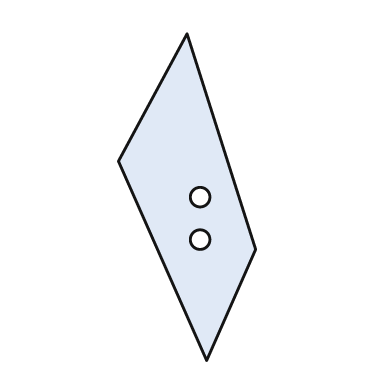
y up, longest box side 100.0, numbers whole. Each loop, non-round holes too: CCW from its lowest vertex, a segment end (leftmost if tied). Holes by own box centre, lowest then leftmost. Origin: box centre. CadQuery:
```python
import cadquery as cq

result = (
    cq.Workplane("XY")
    .moveTo(6.0, -50.0)
    .lineTo(21.0, -16.0)
    .lineTo(0.0, 50.0)
    .lineTo(-21.0, 11.0)
    .close()
    .moveTo(4.0, -13.0)
    .circle(3.0)
    .moveTo(4.0, 0.0)
    .circle(3.0)
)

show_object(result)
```